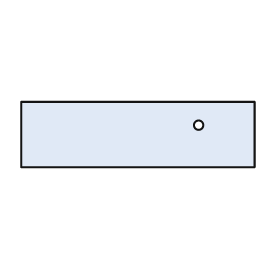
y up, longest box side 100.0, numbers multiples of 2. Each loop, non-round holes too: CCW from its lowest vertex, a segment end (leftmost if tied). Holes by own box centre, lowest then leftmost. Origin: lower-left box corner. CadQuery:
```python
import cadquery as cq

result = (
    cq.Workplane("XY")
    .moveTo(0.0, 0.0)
    .lineTo(100.0, 0.0)
    .lineTo(100.0, 28.0)
    .lineTo(0.0, 28.0)
    .close()
    .moveTo(76.0, 18.0)
    .circle(2.0)
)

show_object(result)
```